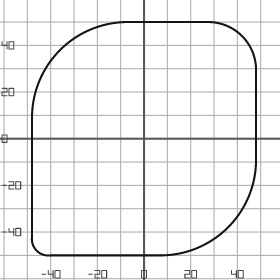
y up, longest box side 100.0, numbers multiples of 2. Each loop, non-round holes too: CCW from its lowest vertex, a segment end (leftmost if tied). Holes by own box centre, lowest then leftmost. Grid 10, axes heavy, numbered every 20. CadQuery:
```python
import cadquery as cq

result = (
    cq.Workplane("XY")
    .moveTo(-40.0, -50.0)
    .lineTo(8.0, -50.0)
    .threePointArc((36.0, -38.0), (48.0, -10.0))
    .lineTo(48.0, 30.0)
    .threePointArc((42.0, 44.0), (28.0, 50.0))
    .lineTo(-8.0, 50.0)
    .threePointArc((-36.0, 38.0), (-48.0, 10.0))
    .lineTo(-48.0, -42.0)
    .threePointArc((-46.0, -48.0), (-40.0, -50.0))
    .close()
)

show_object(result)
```